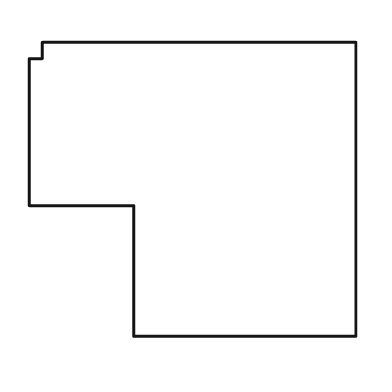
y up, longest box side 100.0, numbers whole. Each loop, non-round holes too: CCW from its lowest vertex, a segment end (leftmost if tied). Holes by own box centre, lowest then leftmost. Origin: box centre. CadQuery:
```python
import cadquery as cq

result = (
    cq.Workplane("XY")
    .moveTo(-18.0, -45.0)
    .lineTo(50.0, -45.0)
    .lineTo(50.0, 45.0)
    .lineTo(-46.0, 45.0)
    .lineTo(-46.0, 40.0)
    .lineTo(-50.0, 40.0)
    .lineTo(-50.0, -5.0)
    .lineTo(-18.0, -5.0)
    .close()
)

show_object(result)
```